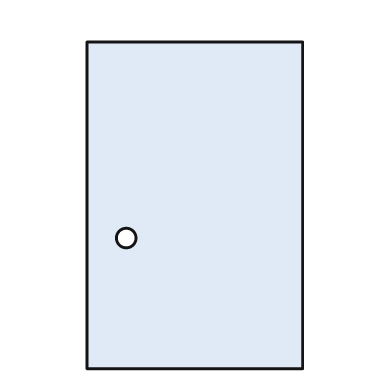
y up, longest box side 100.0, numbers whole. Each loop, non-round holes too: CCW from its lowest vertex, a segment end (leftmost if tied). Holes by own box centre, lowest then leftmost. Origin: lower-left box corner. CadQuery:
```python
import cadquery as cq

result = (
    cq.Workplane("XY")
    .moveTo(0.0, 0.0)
    .lineTo(66.0, 0.0)
    .lineTo(66.0, 100.0)
    .lineTo(0.0, 100.0)
    .close()
    .moveTo(12.0, 40.0)
    .circle(3.0)
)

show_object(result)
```